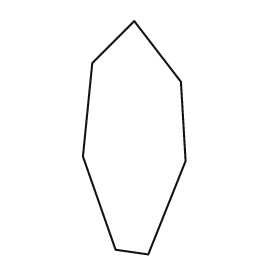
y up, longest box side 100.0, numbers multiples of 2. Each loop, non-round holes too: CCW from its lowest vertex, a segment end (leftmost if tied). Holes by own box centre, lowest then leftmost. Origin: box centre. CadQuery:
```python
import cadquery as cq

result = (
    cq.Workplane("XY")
    .moveTo(6.0, -50.0)
    .lineTo(22.0, -10.0)
    .lineTo(20.0, 24.0)
    .lineTo(0.0, 50.0)
    .lineTo(-18.0, 32.0)
    .lineTo(-22.0, -8.0)
    .lineTo(-8.0, -48.0)
    .close()
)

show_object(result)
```